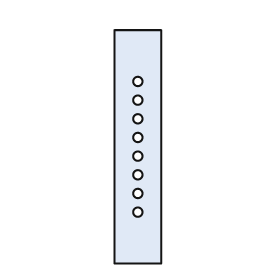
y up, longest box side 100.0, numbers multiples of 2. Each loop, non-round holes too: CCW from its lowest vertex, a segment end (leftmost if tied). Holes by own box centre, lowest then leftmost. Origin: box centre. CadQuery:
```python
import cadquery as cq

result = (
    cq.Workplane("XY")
    .moveTo(-10.0, -50.0)
    .lineTo(10.0, -50.0)
    .lineTo(10.0, 50.0)
    .lineTo(-10.0, 50.0)
    .close()
    .moveTo(0.0, -28.0)
    .circle(2.0)
    .moveTo(0.0, -20.0)
    .circle(2.0)
    .moveTo(0.0, -12.0)
    .circle(2.0)
    .moveTo(0.0, -4.0)
    .circle(2.0)
    .moveTo(0.0, 4.0)
    .circle(2.0)
    .moveTo(0.0, 12.0)
    .circle(2.0)
    .moveTo(0.0, 20.0)
    .circle(2.0)
    .moveTo(0.0, 28.0)
    .circle(2.0)
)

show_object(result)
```